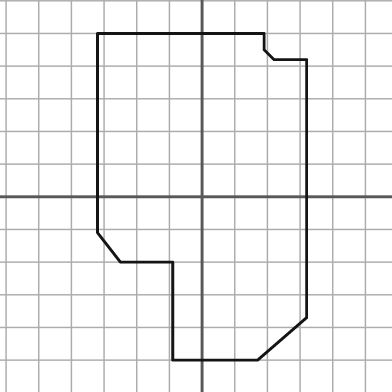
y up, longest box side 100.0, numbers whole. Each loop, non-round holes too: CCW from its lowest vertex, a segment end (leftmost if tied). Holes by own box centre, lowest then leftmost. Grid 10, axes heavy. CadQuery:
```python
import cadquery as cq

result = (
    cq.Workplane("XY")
    .moveTo(-9.0, -50.0)
    .lineTo(17.0, -50.0)
    .lineTo(32.0, -37.0)
    .lineTo(32.0, 42.0)
    .lineTo(22.0, 42.0)
    .lineTo(19.0, 45.0)
    .lineTo(19.0, 50.0)
    .lineTo(-32.0, 50.0)
    .lineTo(-32.0, -11.0)
    .lineTo(-25.0, -20.0)
    .lineTo(-9.0, -20.0)
    .close()
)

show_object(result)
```